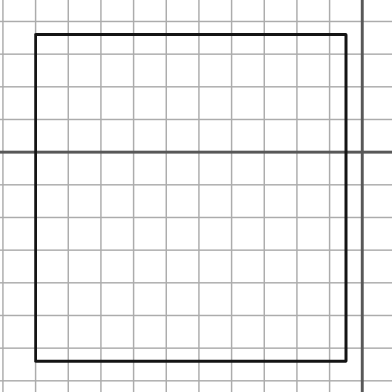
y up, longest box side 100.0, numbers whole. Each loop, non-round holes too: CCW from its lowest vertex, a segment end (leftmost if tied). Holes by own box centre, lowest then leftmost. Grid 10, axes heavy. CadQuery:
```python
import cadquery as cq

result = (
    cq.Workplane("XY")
    .moveTo(-100.0, -64.0)
    .lineTo(-5.0, -64.0)
    .lineTo(-5.0, 36.0)
    .lineTo(-100.0, 36.0)
    .close()
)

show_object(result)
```